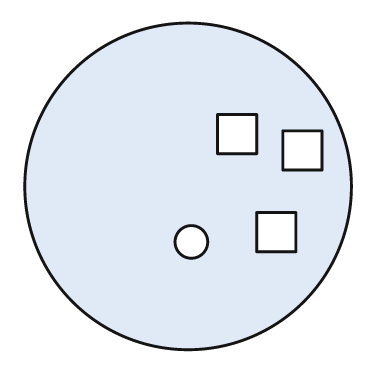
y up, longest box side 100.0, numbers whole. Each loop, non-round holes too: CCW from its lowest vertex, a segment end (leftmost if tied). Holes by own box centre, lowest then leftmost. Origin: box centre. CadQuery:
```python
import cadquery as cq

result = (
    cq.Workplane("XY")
    .moveTo(0.0, 0.0)
    .circle(50.0)
    .moveTo(1.0, -17.0)
    .circle(5.0)
    .moveTo(21.0, -20.0)
    .lineTo(33.0, -20.0)
    .lineTo(33.0, -8.0)
    .lineTo(21.0, -8.0)
    .close()
    .moveTo(29.0, 5.0)
    .lineTo(41.0, 5.0)
    .lineTo(41.0, 17.0)
    .lineTo(29.0, 17.0)
    .close()
    .moveTo(9.0, 10.0)
    .lineTo(21.0, 10.0)
    .lineTo(21.0, 22.0)
    .lineTo(9.0, 22.0)
    .close()
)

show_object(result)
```